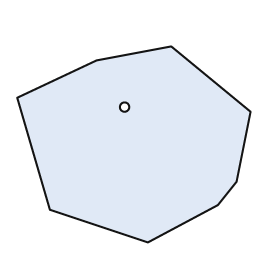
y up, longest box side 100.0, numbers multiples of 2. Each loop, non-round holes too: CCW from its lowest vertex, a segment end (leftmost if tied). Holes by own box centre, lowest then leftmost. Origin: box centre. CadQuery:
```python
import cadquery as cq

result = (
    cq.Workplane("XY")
    .moveTo(6.0, -42.0)
    .lineTo(36.0, -26.0)
    .lineTo(44.0, -16.0)
    .lineTo(50.0, 14.0)
    .lineTo(16.0, 42.0)
    .lineTo(-16.0, 36.0)
    .lineTo(-50.0, 20.0)
    .lineTo(-36.0, -28.0)
    .close()
    .moveTo(-4.0, 16.0)
    .circle(2.0)
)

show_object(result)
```